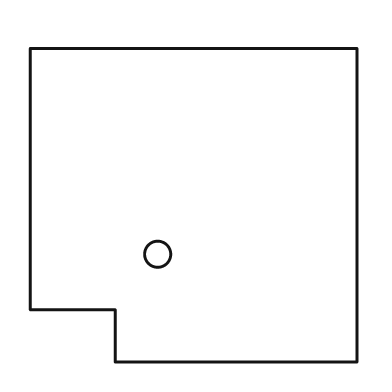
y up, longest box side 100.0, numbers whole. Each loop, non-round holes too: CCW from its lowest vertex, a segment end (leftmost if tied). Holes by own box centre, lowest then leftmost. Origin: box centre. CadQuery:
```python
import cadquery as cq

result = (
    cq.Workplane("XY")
    .moveTo(-24.0, -48.0)
    .lineTo(50.0, -48.0)
    .lineTo(50.0, 48.0)
    .lineTo(-50.0, 48.0)
    .lineTo(-50.0, -32.0)
    .lineTo(-24.0, -32.0)
    .close()
    .moveTo(-11.0, -15.0)
    .circle(4.0)
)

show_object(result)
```